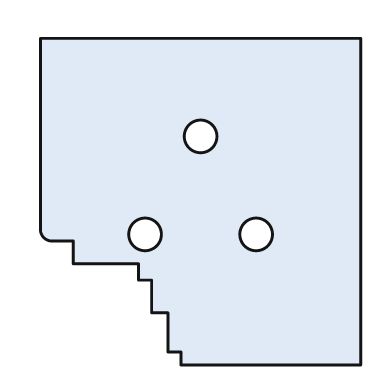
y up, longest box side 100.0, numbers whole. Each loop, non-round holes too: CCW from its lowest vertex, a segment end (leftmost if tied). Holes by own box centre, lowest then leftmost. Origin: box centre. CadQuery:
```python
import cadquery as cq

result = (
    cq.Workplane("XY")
    .moveTo(-6.0, -50.0)
    .lineTo(49.0, -50.0)
    .lineTo(49.0, 50.0)
    .lineTo(-49.0, 50.0)
    .lineTo(-49.0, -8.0)
    .threePointArc((-48.0, -11.0), (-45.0, -12.0))
    .lineTo(-39.0, -12.0)
    .lineTo(-39.0, -19.0)
    .lineTo(-19.0, -19.0)
    .lineTo(-19.0, -24.0)
    .lineTo(-15.0, -24.0)
    .lineTo(-15.0, -34.0)
    .lineTo(-10.0, -34.0)
    .lineTo(-10.0, -46.0)
    .lineTo(-6.0, -46.0)
    .close()
    .moveTo(-17.0, -10.0)
    .circle(5.0)
    .moveTo(17.0, -10.0)
    .circle(5.0)
    .moveTo(0.0, 20.0)
    .circle(5.0)
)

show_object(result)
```